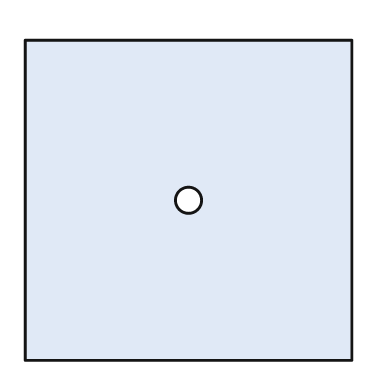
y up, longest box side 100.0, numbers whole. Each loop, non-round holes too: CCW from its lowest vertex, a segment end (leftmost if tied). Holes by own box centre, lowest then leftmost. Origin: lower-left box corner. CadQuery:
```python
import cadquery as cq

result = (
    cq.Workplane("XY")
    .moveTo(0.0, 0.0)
    .lineTo(100.0, 0.0)
    .lineTo(100.0, 98.0)
    .lineTo(0.0, 98.0)
    .close()
    .moveTo(50.0, 49.0)
    .circle(4.0)
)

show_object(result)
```